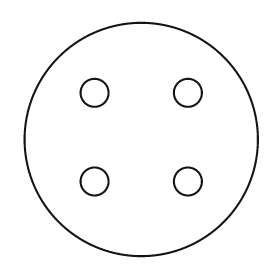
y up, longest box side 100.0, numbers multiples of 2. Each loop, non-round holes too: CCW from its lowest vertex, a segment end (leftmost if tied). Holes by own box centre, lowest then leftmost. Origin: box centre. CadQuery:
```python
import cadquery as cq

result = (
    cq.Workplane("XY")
    .moveTo(0.0, 0.0)
    .circle(50.0)
    .moveTo(-20.0, -18.0)
    .circle(6.0)
    .moveTo(20.0, -18.0)
    .circle(6.0)
    .moveTo(-20.0, 20.0)
    .circle(6.0)
    .moveTo(20.0, 20.0)
    .circle(6.0)
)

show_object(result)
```